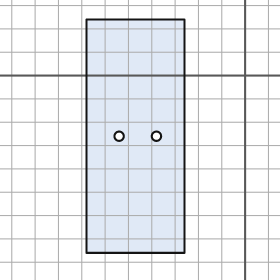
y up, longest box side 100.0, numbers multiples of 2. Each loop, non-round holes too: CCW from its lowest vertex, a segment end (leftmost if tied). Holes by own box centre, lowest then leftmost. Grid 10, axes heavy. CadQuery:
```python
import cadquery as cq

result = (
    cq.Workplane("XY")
    .moveTo(-68.0, -76.0)
    .lineTo(-26.0, -76.0)
    .lineTo(-26.0, 24.0)
    .lineTo(-68.0, 24.0)
    .close()
    .moveTo(-54.0, -26.0)
    .circle(2.0)
    .moveTo(-38.0, -26.0)
    .circle(2.0)
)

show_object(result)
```